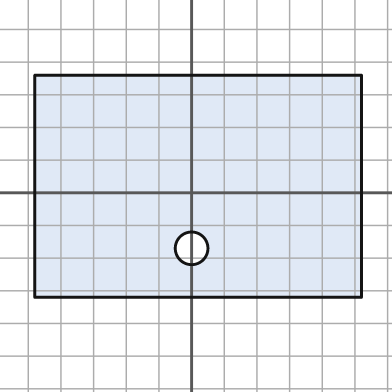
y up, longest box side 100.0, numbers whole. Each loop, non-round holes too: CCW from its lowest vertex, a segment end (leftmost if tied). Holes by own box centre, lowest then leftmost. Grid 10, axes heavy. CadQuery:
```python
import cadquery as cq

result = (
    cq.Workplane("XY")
    .moveTo(-48.0, -32.0)
    .lineTo(52.0, -32.0)
    .lineTo(52.0, 36.0)
    .lineTo(-48.0, 36.0)
    .close()
    .moveTo(0.0, -17.0)
    .circle(5.0)
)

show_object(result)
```